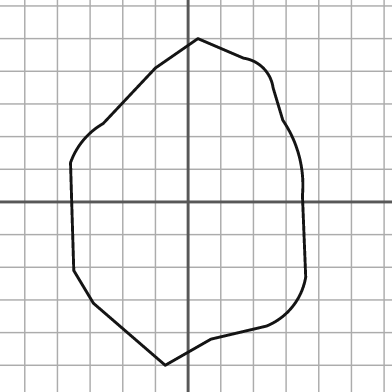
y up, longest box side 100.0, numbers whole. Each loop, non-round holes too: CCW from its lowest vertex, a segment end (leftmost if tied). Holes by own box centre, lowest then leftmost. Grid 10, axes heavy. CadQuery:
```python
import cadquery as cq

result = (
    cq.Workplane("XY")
    .moveTo(-7.0, -50.0)
    .lineTo(7.0, -42.0)
    .lineTo(24.0, -38.0)
    .threePointArc((32.0, -32.0), (36.0, -23.0))
    .lineTo(35.0, 2.0)
    .threePointArc((34.0, 14.0), (29.0, 25.0))
    .lineTo(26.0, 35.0)
    .threePointArc((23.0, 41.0), (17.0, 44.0))
    .lineTo(3.0, 50.0)
    .lineTo(-10.0, 41.0)
    .lineTo(-26.0, 24.0)
    .threePointArc((-32.0, 19.0), (-36.0, 12.0))
    .lineTo(-35.0, -21.0)
    .lineTo(-29.0, -31.0)
    .close()
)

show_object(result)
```